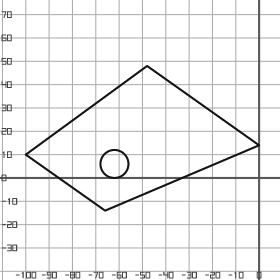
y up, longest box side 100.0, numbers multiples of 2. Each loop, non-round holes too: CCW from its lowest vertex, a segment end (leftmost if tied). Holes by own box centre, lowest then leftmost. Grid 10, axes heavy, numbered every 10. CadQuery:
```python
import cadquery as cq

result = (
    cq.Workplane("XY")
    .moveTo(-66.0, -14.0)
    .lineTo(0.0, 14.0)
    .lineTo(-48.0, 48.0)
    .lineTo(-100.0, 10.0)
    .close()
    .moveTo(-62.0, 6.0)
    .circle(6.0)
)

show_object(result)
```